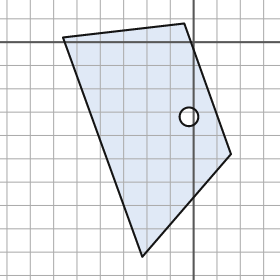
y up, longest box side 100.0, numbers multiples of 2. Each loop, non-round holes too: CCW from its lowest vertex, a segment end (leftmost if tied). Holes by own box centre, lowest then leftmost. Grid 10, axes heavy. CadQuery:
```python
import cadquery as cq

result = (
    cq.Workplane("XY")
    .moveTo(-22.0, -92.0)
    .lineTo(16.0, -48.0)
    .lineTo(-4.0, 8.0)
    .lineTo(-56.0, 2.0)
    .close()
    .moveTo(-2.0, -32.0)
    .circle(4.0)
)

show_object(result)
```